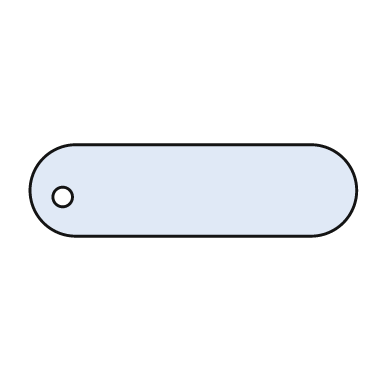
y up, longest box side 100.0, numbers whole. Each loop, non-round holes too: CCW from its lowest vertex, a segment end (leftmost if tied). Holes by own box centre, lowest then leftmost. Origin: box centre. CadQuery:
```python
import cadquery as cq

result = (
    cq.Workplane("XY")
    .moveTo(-36.0, -14.0)
    .lineTo(36.0, -14.0)
    .threePointArc((50.0, 0.0), (36.0, 14.0))
    .lineTo(-36.0, 14.0)
    .threePointArc((-50.0, 0.0), (-36.0, -14.0))
    .close()
    .moveTo(-40.0, -2.0)
    .circle(3.0)
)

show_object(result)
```